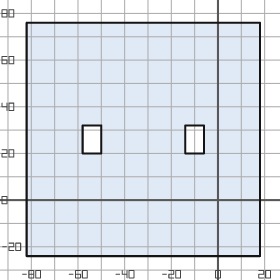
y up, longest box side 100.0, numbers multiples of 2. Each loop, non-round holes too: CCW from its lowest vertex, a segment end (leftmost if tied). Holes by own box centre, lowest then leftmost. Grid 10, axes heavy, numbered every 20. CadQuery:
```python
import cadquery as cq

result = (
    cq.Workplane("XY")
    .moveTo(-82.0, -24.0)
    .lineTo(18.0, -24.0)
    .lineTo(18.0, 76.0)
    .lineTo(-82.0, 76.0)
    .close()
    .moveTo(-58.0, 20.0)
    .lineTo(-50.0, 20.0)
    .lineTo(-50.0, 32.0)
    .lineTo(-58.0, 32.0)
    .close()
    .moveTo(-14.0, 20.0)
    .lineTo(-6.0, 20.0)
    .lineTo(-6.0, 32.0)
    .lineTo(-14.0, 32.0)
    .close()
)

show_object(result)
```